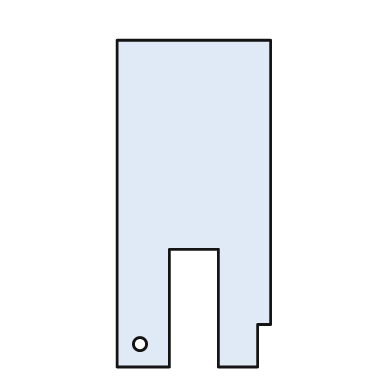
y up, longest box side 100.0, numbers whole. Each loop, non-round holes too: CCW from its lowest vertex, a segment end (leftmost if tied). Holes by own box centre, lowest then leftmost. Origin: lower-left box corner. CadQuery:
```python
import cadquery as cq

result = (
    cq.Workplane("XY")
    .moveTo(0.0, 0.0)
    .lineTo(16.0, 0.0)
    .lineTo(16.0, 36.0)
    .lineTo(31.0, 36.0)
    .lineTo(31.0, 0.0)
    .lineTo(43.0, 0.0)
    .lineTo(43.0, 13.0)
    .lineTo(47.0, 13.0)
    .lineTo(47.0, 100.0)
    .lineTo(0.0, 100.0)
    .close()
    .moveTo(7.0, 7.0)
    .circle(2.0)
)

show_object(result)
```